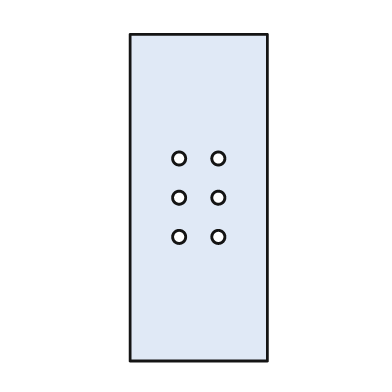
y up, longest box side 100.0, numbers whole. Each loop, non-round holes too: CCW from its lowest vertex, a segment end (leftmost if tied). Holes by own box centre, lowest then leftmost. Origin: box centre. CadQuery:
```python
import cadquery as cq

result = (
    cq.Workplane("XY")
    .moveTo(-21.0, -50.0)
    .lineTo(21.0, -50.0)
    .lineTo(21.0, 50.0)
    .lineTo(-21.0, 50.0)
    .close()
    .moveTo(-6.0, -12.0)
    .circle(2.0)
    .moveTo(6.0, -12.0)
    .circle(2.0)
    .moveTo(-6.0, 0.0)
    .circle(2.0)
    .moveTo(6.0, 0.0)
    .circle(2.0)
    .moveTo(-6.0, 12.0)
    .circle(2.0)
    .moveTo(6.0, 12.0)
    .circle(2.0)
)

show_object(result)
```